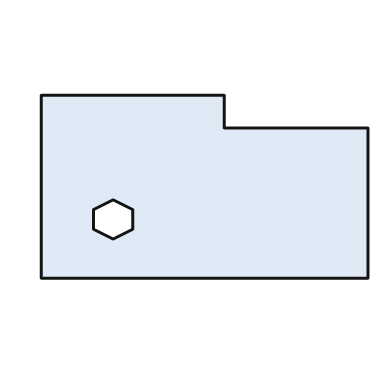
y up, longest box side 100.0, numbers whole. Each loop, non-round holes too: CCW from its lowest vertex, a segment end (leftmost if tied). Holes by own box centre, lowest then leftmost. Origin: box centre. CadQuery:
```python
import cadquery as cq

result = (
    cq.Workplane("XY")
    .moveTo(-50.0, -28.0)
    .lineTo(50.0, -28.0)
    .lineTo(50.0, 18.0)
    .lineTo(6.0, 18.0)
    .lineTo(6.0, 28.0)
    .lineTo(-50.0, 28.0)
    .close()
    .moveTo(-28.0, -16.0)
    .lineTo(-22.0, -13.0)
    .lineTo(-22.0, -7.0)
    .lineTo(-28.0, -4.0)
    .lineTo(-34.0, -7.0)
    .lineTo(-34.0, -13.0)
    .close()
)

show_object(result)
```